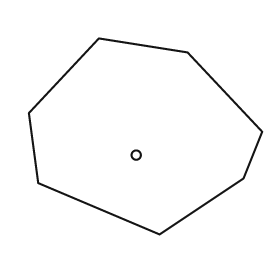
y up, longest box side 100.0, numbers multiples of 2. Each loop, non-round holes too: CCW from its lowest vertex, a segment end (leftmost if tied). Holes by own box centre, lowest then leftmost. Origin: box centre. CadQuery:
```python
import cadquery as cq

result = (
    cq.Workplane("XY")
    .moveTo(6.0, -42.0)
    .lineTo(42.0, -18.0)
    .lineTo(50.0, 2.0)
    .lineTo(18.0, 36.0)
    .lineTo(-20.0, 42.0)
    .lineTo(-50.0, 10.0)
    .lineTo(-46.0, -20.0)
    .close()
    .moveTo(-4.0, -8.0)
    .circle(2.0)
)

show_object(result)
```